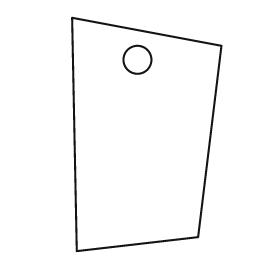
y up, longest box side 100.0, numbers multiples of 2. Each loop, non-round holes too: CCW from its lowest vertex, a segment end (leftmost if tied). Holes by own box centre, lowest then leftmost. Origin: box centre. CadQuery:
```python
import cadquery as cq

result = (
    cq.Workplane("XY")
    .moveTo(-30.0, -50.0)
    .lineTo(22.0, -44.0)
    .lineTo(32.0, 38.0)
    .lineTo(-32.0, 50.0)
    .close()
    .moveTo(-4.0, 32.0)
    .circle(6.0)
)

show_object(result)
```